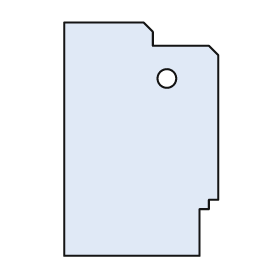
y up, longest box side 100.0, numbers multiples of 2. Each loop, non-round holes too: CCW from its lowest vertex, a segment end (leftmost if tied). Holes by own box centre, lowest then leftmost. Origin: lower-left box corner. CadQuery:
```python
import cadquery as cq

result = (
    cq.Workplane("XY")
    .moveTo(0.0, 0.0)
    .lineTo(58.0, 0.0)
    .lineTo(58.0, 20.0)
    .lineTo(62.0, 20.0)
    .lineTo(62.0, 24.0)
    .lineTo(66.0, 24.0)
    .lineTo(66.0, 86.0)
    .lineTo(62.0, 90.0)
    .lineTo(38.0, 90.0)
    .lineTo(38.0, 96.0)
    .lineTo(34.0, 100.0)
    .lineTo(0.0, 100.0)
    .close()
    .moveTo(44.0, 76.0)
    .circle(4.0)
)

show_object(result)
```